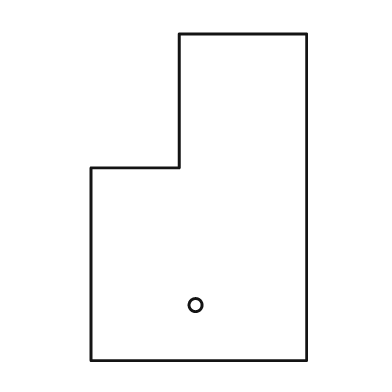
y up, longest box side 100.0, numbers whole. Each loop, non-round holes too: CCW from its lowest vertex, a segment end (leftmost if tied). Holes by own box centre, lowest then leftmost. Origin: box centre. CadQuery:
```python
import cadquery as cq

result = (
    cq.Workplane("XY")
    .moveTo(-33.0, -50.0)
    .lineTo(33.0, -50.0)
    .lineTo(33.0, 50.0)
    .lineTo(-6.0, 50.0)
    .lineTo(-6.0, 9.0)
    .lineTo(-33.0, 9.0)
    .close()
    .moveTo(-1.0, -33.0)
    .circle(2.0)
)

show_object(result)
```